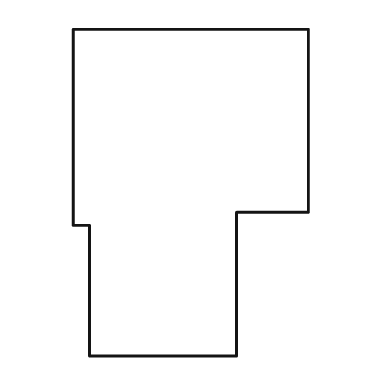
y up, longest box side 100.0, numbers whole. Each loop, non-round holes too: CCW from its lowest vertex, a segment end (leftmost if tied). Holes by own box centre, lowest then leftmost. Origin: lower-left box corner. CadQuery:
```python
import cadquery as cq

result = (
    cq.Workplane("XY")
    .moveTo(5.0, 0.0)
    .lineTo(50.0, 0.0)
    .lineTo(50.0, 44.0)
    .lineTo(72.0, 44.0)
    .lineTo(72.0, 100.0)
    .lineTo(0.0, 100.0)
    .lineTo(0.0, 40.0)
    .lineTo(5.0, 40.0)
    .close()
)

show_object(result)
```